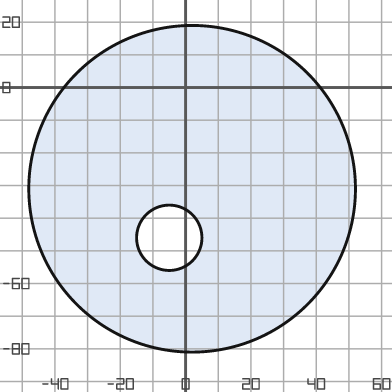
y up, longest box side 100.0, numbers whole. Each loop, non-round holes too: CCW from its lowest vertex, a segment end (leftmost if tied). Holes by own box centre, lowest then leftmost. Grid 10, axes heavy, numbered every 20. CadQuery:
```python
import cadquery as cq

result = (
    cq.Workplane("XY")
    .moveTo(2.0, -31.0)
    .circle(50.0)
    .moveTo(-5.0, -46.0)
    .circle(10.0)
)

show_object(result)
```